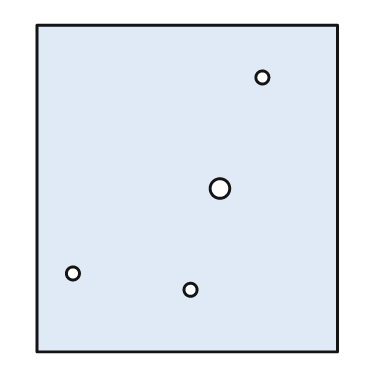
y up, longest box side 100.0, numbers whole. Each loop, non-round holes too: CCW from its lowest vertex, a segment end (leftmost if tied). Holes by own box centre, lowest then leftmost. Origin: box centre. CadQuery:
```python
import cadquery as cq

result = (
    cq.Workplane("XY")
    .moveTo(-46.0, -50.0)
    .lineTo(46.0, -50.0)
    .lineTo(46.0, 50.0)
    .lineTo(-46.0, 50.0)
    .close()
    .moveTo(1.0, -31.0)
    .circle(2.0)
    .moveTo(-35.0, -26.0)
    .circle(2.0)
    .moveTo(10.0, 0.0)
    .circle(3.0)
    .moveTo(23.0, 34.0)
    .circle(2.0)
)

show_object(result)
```